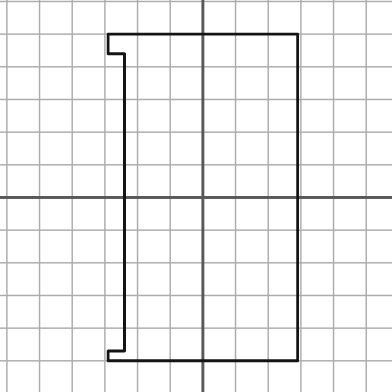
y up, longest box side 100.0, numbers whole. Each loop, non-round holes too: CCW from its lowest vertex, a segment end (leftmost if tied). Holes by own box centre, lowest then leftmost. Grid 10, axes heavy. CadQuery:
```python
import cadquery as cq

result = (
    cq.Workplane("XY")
    .moveTo(-29.0, -50.0)
    .lineTo(29.0, -50.0)
    .lineTo(29.0, 50.0)
    .lineTo(-29.0, 50.0)
    .lineTo(-29.0, 44.0)
    .lineTo(-24.0, 44.0)
    .lineTo(-24.0, -47.0)
    .lineTo(-29.0, -47.0)
    .close()
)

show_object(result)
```